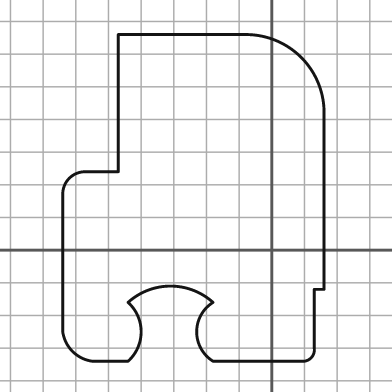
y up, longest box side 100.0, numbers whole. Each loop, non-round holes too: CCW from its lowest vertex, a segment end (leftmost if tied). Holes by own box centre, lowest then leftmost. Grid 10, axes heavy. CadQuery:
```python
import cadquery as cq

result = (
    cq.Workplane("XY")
    .moveTo(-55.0, -34.0)
    .lineTo(-44.0, -34.0)
    .threePointArc((-40.0, -25.0), (-44.0, -16.0))
    .threePointArc((-31.0, -11.0), (-18.0, -16.0))
    .threePointArc((-23.0, -25.0), (-18.0, -34.0))
    .lineTo(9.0, -34.0)
    .threePointArc((12.0, -33.0), (13.0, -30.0))
    .lineTo(13.0, -12.0)
    .lineTo(16.0, -12.0)
    .lineTo(16.0, 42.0)
    .threePointArc((9.0, 59.0), (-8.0, 66.0))
    .lineTo(-47.0, 66.0)
    .lineTo(-47.0, 24.0)
    .lineTo(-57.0, 24.0)
    .threePointArc((-62.0, 22.0), (-64.0, 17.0))
    .lineTo(-64.0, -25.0)
    .threePointArc((-61.0, -31.0), (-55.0, -34.0))
    .close()
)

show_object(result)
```